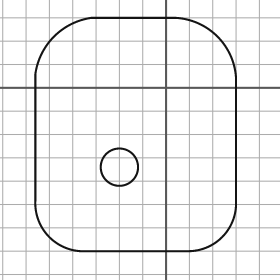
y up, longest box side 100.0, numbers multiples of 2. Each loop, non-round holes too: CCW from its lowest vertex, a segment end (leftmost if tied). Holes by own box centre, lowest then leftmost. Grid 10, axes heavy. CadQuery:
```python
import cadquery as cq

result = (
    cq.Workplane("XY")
    .moveTo(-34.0, -70.0)
    .lineTo(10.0, -70.0)
    .threePointArc((24.0, -64.0), (30.0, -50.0))
    .lineTo(30.0, 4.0)
    .threePointArc((22.0, 22.0), (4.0, 30.0))
    .lineTo(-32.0, 30.0)
    .threePointArc((-48.0, 22.0), (-56.0, 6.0))
    .lineTo(-56.0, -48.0)
    .threePointArc((-50.0, -64.0), (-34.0, -70.0))
    .close()
    .moveTo(-20.0, -34.0)
    .circle(8.0)
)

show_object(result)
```